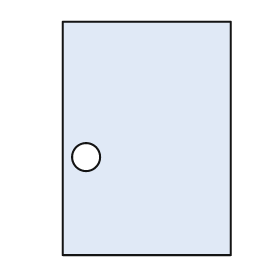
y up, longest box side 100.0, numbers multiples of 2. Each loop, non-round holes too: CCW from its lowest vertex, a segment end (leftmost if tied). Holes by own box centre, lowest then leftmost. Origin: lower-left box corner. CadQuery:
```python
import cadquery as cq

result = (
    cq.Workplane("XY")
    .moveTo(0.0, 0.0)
    .lineTo(72.0, 0.0)
    .lineTo(72.0, 100.0)
    .lineTo(0.0, 100.0)
    .close()
    .moveTo(10.0, 42.0)
    .circle(6.0)
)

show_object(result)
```